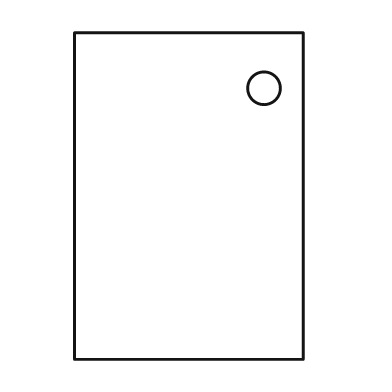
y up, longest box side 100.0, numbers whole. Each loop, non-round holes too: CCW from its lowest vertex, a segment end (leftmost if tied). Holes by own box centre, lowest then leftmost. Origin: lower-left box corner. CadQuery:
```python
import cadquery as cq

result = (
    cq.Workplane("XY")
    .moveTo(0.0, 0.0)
    .lineTo(70.0, 0.0)
    .lineTo(70.0, 100.0)
    .lineTo(0.0, 100.0)
    .close()
    .moveTo(58.0, 83.0)
    .circle(5.0)
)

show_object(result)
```